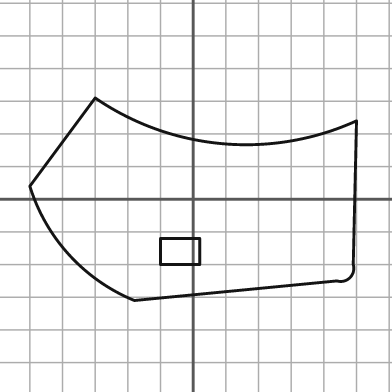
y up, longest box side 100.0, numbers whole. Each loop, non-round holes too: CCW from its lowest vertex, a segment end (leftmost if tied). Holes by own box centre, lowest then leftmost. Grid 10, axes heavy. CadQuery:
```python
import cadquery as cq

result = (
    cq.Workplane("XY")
    .moveTo(-18.0, -31.0)
    .lineTo(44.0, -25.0)
    .threePointArc((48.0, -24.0), (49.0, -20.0))
    .lineTo(50.0, 24.0)
    .threePointArc((9.0, 17.0), (-30.0, 31.0))
    .lineTo(-50.0, 4.0)
    .threePointArc((-38.0, -17.0), (-18.0, -31.0))
    .close()
    .moveTo(-10.0, -20.0)
    .lineTo(2.0, -20.0)
    .lineTo(2.0, -12.0)
    .lineTo(-10.0, -12.0)
    .close()
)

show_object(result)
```